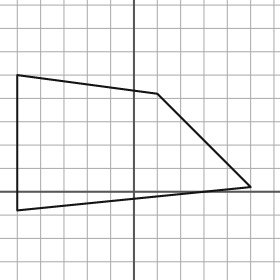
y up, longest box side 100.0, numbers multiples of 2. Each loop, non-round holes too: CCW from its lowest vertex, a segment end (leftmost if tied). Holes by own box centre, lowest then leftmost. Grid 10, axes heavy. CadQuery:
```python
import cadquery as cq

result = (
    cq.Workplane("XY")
    .moveTo(-50.0, -8.0)
    .lineTo(50.0, 2.0)
    .lineTo(10.0, 42.0)
    .lineTo(-50.0, 50.0)
    .close()
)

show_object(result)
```